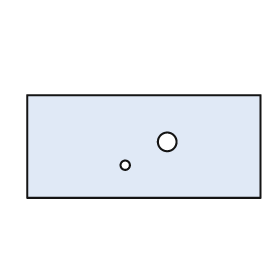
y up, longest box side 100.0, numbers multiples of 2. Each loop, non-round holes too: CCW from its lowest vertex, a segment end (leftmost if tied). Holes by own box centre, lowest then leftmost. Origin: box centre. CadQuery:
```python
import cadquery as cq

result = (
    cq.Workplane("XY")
    .moveTo(-50.0, -22.0)
    .lineTo(50.0, -22.0)
    .lineTo(50.0, 22.0)
    .lineTo(-50.0, 22.0)
    .close()
    .moveTo(-8.0, -8.0)
    .circle(2.0)
    .moveTo(10.0, 2.0)
    .circle(4.0)
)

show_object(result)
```